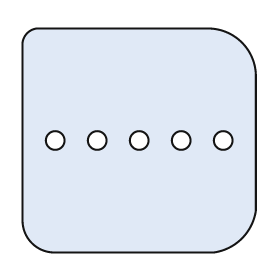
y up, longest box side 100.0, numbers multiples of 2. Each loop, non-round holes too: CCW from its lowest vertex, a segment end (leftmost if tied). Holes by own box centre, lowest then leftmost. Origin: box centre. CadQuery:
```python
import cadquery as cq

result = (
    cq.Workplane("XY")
    .moveTo(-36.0, -48.0)
    .lineTo(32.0, -48.0)
    .threePointArc((44.0, -42.0), (50.0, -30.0))
    .lineTo(50.0, 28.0)
    .threePointArc((44.0, 42.0), (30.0, 48.0))
    .lineTo(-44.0, 48.0)
    .threePointArc((-48.0, 46.0), (-50.0, 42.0))
    .lineTo(-50.0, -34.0)
    .threePointArc((-46.0, -44.0), (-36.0, -48.0))
    .close()
    .moveTo(-36.0, 0.0)
    .circle(4.0)
    .moveTo(-18.0, 0.0)
    .circle(4.0)
    .moveTo(0.0, 0.0)
    .circle(4.0)
    .moveTo(18.0, 0.0)
    .circle(4.0)
    .moveTo(36.0, 0.0)
    .circle(4.0)
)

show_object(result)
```